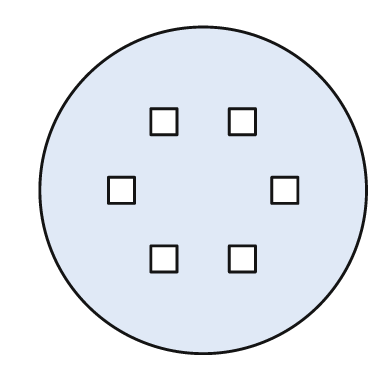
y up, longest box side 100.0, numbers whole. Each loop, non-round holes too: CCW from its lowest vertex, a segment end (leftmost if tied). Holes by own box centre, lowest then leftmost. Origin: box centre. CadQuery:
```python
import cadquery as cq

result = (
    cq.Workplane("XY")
    .moveTo(0.0, 0.0)
    .circle(50.0)
    .moveTo(-16.0, -25.0)
    .lineTo(-8.0, -25.0)
    .lineTo(-8.0, -17.0)
    .lineTo(-16.0, -17.0)
    .close()
    .moveTo(8.0, -25.0)
    .lineTo(16.0, -25.0)
    .lineTo(16.0, -17.0)
    .lineTo(8.0, -17.0)
    .close()
    .moveTo(-29.0, -4.0)
    .lineTo(-21.0, -4.0)
    .lineTo(-21.0, 4.0)
    .lineTo(-29.0, 4.0)
    .close()
    .moveTo(21.0, -4.0)
    .lineTo(29.0, -4.0)
    .lineTo(29.0, 4.0)
    .lineTo(21.0, 4.0)
    .close()
    .moveTo(-16.0, 17.0)
    .lineTo(-8.0, 17.0)
    .lineTo(-8.0, 25.0)
    .lineTo(-16.0, 25.0)
    .close()
    .moveTo(8.0, 17.0)
    .lineTo(16.0, 17.0)
    .lineTo(16.0, 25.0)
    .lineTo(8.0, 25.0)
    .close()
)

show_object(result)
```